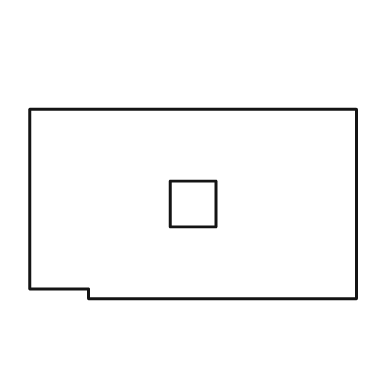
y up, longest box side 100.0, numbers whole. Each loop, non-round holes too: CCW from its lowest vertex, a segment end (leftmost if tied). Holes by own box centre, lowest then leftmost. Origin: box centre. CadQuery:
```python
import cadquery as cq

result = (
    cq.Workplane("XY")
    .moveTo(-32.0, -29.0)
    .lineTo(50.0, -29.0)
    .lineTo(50.0, 29.0)
    .lineTo(-50.0, 29.0)
    .lineTo(-50.0, -26.0)
    .lineTo(-32.0, -26.0)
    .close()
    .moveTo(-7.0, -7.0)
    .lineTo(7.0, -7.0)
    .lineTo(7.0, 7.0)
    .lineTo(-7.0, 7.0)
    .close()
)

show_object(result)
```